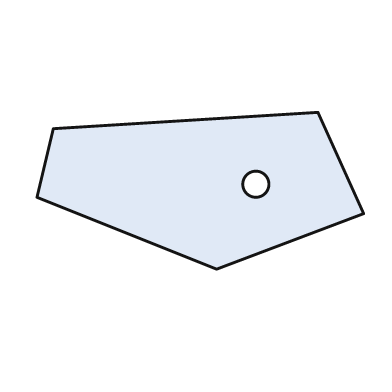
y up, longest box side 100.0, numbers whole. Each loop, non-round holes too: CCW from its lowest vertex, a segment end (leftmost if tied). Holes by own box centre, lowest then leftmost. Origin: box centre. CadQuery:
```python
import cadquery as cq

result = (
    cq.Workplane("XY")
    .moveTo(5.0, -24.0)
    .lineTo(50.0, -7.0)
    .lineTo(36.0, 24.0)
    .lineTo(-45.0, 19.0)
    .lineTo(-50.0, -2.0)
    .close()
    .moveTo(17.0, 2.0)
    .circle(4.0)
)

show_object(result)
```